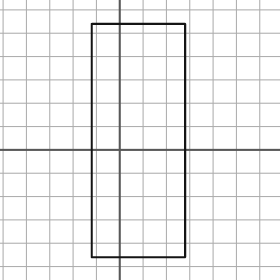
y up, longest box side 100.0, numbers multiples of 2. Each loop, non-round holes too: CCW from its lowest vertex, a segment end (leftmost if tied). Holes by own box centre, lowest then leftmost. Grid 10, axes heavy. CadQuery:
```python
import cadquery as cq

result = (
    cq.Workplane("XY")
    .moveTo(-12.0, -46.0)
    .lineTo(28.0, -46.0)
    .lineTo(28.0, 54.0)
    .lineTo(-12.0, 54.0)
    .close()
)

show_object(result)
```